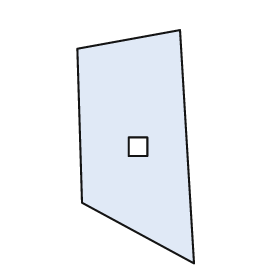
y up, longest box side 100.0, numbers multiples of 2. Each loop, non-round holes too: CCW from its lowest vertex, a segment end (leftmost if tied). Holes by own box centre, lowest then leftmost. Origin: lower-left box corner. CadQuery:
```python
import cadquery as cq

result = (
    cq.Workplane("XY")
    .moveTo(50.0, 0.0)
    .lineTo(44.0, 100.0)
    .lineTo(0.0, 92.0)
    .lineTo(2.0, 26.0)
    .close()
    .moveTo(22.0, 46.0)
    .lineTo(30.0, 46.0)
    .lineTo(30.0, 54.0)
    .lineTo(22.0, 54.0)
    .close()
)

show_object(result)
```